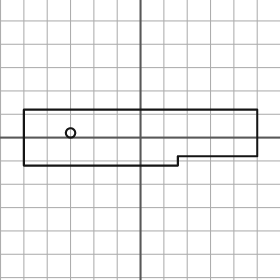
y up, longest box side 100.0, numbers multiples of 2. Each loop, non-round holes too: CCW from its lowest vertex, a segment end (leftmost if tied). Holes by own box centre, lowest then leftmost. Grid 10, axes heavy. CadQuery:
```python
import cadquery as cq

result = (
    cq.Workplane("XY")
    .moveTo(-50.0, -12.0)
    .lineTo(16.0, -12.0)
    .lineTo(16.0, -8.0)
    .lineTo(50.0, -8.0)
    .lineTo(50.0, 12.0)
    .lineTo(-50.0, 12.0)
    .close()
    .moveTo(-30.0, 2.0)
    .circle(2.0)
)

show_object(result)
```